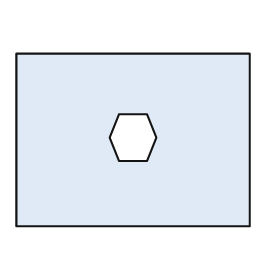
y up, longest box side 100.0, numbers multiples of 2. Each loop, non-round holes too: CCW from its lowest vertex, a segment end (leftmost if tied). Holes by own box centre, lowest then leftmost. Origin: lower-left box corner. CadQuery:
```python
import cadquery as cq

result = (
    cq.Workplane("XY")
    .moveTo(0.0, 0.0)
    .lineTo(100.0, 0.0)
    .lineTo(100.0, 74.0)
    .lineTo(0.0, 74.0)
    .close()
    .moveTo(44.0, 28.0)
    .lineTo(56.0, 28.0)
    .lineTo(60.0, 38.0)
    .lineTo(56.0, 48.0)
    .lineTo(44.0, 48.0)
    .lineTo(40.0, 38.0)
    .close()
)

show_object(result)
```